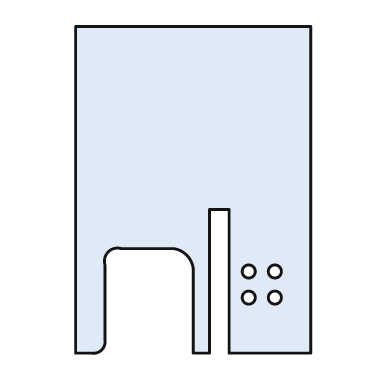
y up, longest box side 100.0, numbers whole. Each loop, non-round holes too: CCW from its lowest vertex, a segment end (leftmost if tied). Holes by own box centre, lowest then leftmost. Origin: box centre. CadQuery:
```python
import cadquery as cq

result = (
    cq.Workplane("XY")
    .moveTo(-36.0, -50.0)
    .lineTo(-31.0, -50.0)
    .threePointArc((-28.0, -49.0), (-27.0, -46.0))
    .lineTo(-27.0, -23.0)
    .threePointArc((-26.0, -19.0), (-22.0, -18.0))
    .lineTo(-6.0, -18.0)
    .threePointArc((-2.0, -20.0), (0.0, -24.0))
    .lineTo(0.0, -50.0)
    .lineTo(5.0, -50.0)
    .lineTo(5.0, -6.0)
    .lineTo(11.0, -6.0)
    .lineTo(11.0, -50.0)
    .lineTo(36.0, -50.0)
    .lineTo(36.0, 50.0)
    .lineTo(-36.0, 50.0)
    .close()
    .moveTo(17.0, -33.0)
    .circle(2.0)
    .moveTo(25.0, -33.0)
    .circle(2.0)
    .moveTo(17.0, -25.0)
    .circle(2.0)
    .moveTo(25.0, -25.0)
    .circle(2.0)
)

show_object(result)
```